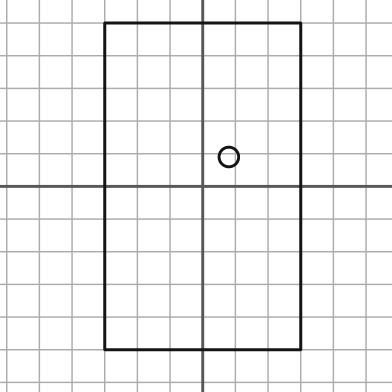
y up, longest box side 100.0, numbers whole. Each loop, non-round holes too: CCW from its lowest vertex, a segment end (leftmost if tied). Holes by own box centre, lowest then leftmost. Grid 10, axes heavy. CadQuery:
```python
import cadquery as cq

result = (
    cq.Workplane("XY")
    .moveTo(-30.0, -50.0)
    .lineTo(30.0, -50.0)
    .lineTo(30.0, 50.0)
    .lineTo(-30.0, 50.0)
    .close()
    .moveTo(8.0, 9.0)
    .circle(3.0)
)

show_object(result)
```